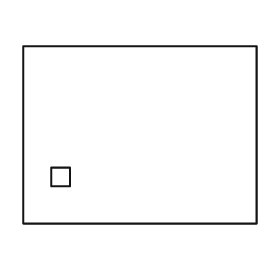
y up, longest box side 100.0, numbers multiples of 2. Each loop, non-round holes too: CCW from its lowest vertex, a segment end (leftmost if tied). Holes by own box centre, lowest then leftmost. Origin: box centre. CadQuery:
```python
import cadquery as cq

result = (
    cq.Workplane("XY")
    .moveTo(-50.0, -38.0)
    .lineTo(50.0, -38.0)
    .lineTo(50.0, 38.0)
    .lineTo(-50.0, 38.0)
    .close()
    .moveTo(-38.0, -22.0)
    .lineTo(-30.0, -22.0)
    .lineTo(-30.0, -14.0)
    .lineTo(-38.0, -14.0)
    .close()
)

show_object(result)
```